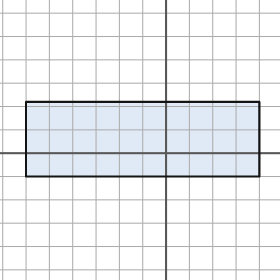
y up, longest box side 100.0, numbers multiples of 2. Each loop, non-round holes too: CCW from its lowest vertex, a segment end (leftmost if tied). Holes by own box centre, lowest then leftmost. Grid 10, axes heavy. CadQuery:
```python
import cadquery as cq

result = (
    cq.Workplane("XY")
    .moveTo(-60.0, -10.0)
    .lineTo(40.0, -10.0)
    .lineTo(40.0, 22.0)
    .lineTo(-60.0, 22.0)
    .close()
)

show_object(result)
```